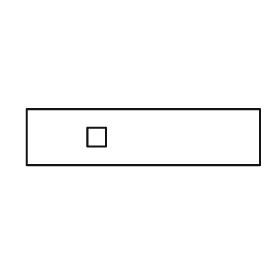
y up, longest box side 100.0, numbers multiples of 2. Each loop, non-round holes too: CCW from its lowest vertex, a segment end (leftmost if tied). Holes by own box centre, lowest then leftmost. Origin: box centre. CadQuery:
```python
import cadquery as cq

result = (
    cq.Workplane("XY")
    .moveTo(-50.0, -12.0)
    .lineTo(50.0, -12.0)
    .lineTo(50.0, 12.0)
    .lineTo(-50.0, 12.0)
    .close()
    .moveTo(-24.0, -4.0)
    .lineTo(-16.0, -4.0)
    .lineTo(-16.0, 4.0)
    .lineTo(-24.0, 4.0)
    .close()
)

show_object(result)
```